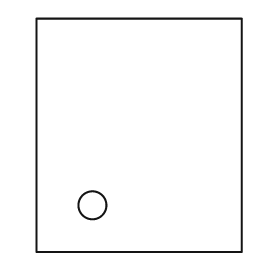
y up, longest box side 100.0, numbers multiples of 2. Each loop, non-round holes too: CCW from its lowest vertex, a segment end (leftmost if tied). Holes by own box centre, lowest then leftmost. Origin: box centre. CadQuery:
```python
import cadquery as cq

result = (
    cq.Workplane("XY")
    .moveTo(-44.0, -50.0)
    .lineTo(44.0, -50.0)
    .lineTo(44.0, 50.0)
    .lineTo(-44.0, 50.0)
    .close()
    .moveTo(-20.0, -30.0)
    .circle(6.0)
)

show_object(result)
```